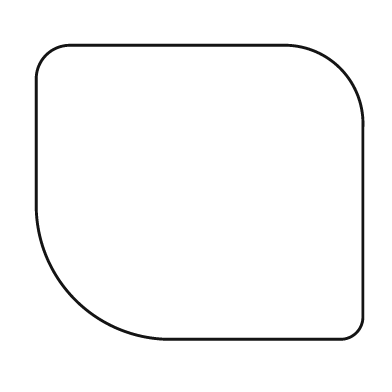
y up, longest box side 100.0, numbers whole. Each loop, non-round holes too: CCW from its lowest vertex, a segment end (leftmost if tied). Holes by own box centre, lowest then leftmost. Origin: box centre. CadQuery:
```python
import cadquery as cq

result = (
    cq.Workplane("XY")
    .moveTo(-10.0, -45.0)
    .lineTo(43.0, -45.0)
    .threePointArc((48.0, -43.0), (50.0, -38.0))
    .lineTo(50.0, 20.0)
    .threePointArc((43.0, 38.0), (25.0, 45.0))
    .lineTo(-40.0, 45.0)
    .threePointArc((-47.0, 42.0), (-50.0, 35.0))
    .lineTo(-50.0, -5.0)
    .threePointArc((-38.0, -33.0), (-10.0, -45.0))
    .close()
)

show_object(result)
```